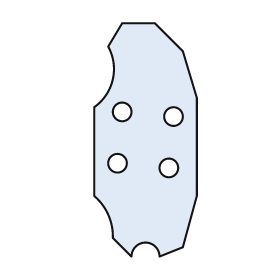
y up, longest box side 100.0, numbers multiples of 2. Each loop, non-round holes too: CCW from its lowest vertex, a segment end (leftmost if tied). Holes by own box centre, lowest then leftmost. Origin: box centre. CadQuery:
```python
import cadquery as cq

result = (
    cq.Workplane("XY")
    .moveTo(-6.0, -50.0)
    .threePointArc((0.0, -44.0), (6.0, -50.0))
    .lineTo(16.0, -46.0)
    .lineTo(22.0, -24.0)
    .lineTo(22.0, 18.0)
    .lineTo(16.0, 38.0)
    .lineTo(4.0, 50.0)
    .lineTo(-10.0, 50.0)
    .lineTo(-16.0, 40.0)
    .threePointArc((-14.0, 26.0), (-22.0, 14.0))
    .lineTo(-22.0, -24.0)
    .threePointArc((-16.0, -32.0), (-14.0, -42.0))
    .close()
    .moveTo(10.0, -12.0)
    .circle(4.0)
    .moveTo(-12.0, -10.0)
    .circle(4.0)
    .moveTo(12.0, 10.0)
    .circle(4.0)
    .moveTo(-10.0, 12.0)
    .circle(4.0)
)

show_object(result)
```